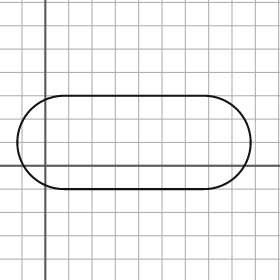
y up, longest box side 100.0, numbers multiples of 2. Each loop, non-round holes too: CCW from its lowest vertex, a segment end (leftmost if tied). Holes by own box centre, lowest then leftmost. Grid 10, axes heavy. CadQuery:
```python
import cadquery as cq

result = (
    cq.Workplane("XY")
    .moveTo(8.0, -10.0)
    .lineTo(68.0, -10.0)
    .threePointArc((88.0, 10.0), (68.0, 30.0))
    .lineTo(8.0, 30.0)
    .threePointArc((-12.0, 10.0), (8.0, -10.0))
    .close()
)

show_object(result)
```